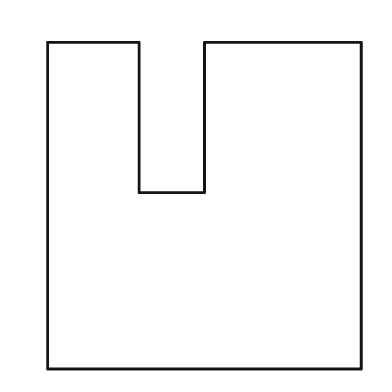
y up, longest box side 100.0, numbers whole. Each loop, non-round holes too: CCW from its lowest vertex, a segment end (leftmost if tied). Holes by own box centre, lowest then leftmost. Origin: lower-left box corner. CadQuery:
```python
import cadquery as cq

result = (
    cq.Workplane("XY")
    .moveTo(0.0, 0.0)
    .lineTo(96.0, 0.0)
    .lineTo(96.0, 100.0)
    .lineTo(48.0, 100.0)
    .lineTo(48.0, 54.0)
    .lineTo(28.0, 54.0)
    .lineTo(28.0, 100.0)
    .lineTo(0.0, 100.0)
    .close()
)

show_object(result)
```